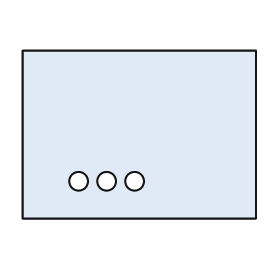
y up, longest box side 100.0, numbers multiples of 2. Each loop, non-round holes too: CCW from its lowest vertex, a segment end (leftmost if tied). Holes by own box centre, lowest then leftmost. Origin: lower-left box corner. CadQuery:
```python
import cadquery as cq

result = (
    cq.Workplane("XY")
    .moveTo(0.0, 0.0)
    .lineTo(100.0, 0.0)
    .lineTo(100.0, 72.0)
    .lineTo(0.0, 72.0)
    .close()
    .moveTo(24.0, 16.0)
    .circle(4.0)
    .moveTo(36.0, 16.0)
    .circle(4.0)
    .moveTo(48.0, 16.0)
    .circle(4.0)
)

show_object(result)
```